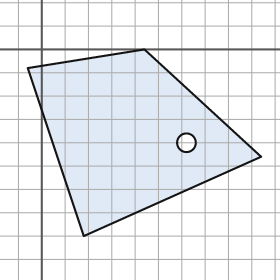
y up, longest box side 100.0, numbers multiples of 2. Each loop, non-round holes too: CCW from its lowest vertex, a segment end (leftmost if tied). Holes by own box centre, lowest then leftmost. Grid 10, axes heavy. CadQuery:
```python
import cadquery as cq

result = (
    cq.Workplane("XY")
    .moveTo(18.0, -80.0)
    .lineTo(94.0, -46.0)
    .lineTo(44.0, 0.0)
    .lineTo(-6.0, -8.0)
    .close()
    .moveTo(62.0, -40.0)
    .circle(4.0)
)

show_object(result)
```